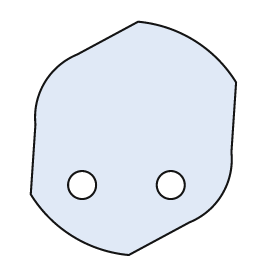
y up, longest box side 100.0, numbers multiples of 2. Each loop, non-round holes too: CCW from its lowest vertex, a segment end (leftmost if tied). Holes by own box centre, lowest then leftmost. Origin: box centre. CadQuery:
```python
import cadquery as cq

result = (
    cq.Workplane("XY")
    .moveTo(-2.0, -50.0)
    .lineTo(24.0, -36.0)
    .threePointArc((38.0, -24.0), (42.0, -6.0))
    .lineTo(44.0, 24.0)
    .threePointArc((26.0, 42.0), (2.0, 50.0))
    .lineTo(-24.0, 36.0)
    .threePointArc((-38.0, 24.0), (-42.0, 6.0))
    .lineTo(-44.0, -24.0)
    .threePointArc((-26.0, -42.0), (-2.0, -50.0))
    .close()
    .moveTo(-22.0, -20.0)
    .circle(6.0)
    .moveTo(16.0, -20.0)
    .circle(6.0)
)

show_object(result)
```